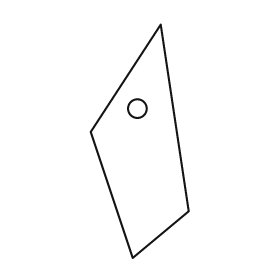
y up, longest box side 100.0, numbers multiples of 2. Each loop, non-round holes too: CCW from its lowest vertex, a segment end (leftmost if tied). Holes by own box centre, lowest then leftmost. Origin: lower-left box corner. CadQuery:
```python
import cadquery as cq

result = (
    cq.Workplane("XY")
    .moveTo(18.0, 0.0)
    .lineTo(42.0, 20.0)
    .lineTo(30.0, 100.0)
    .lineTo(0.0, 54.0)
    .close()
    .moveTo(20.0, 64.0)
    .circle(4.0)
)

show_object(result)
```